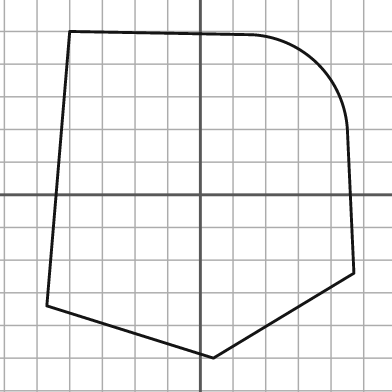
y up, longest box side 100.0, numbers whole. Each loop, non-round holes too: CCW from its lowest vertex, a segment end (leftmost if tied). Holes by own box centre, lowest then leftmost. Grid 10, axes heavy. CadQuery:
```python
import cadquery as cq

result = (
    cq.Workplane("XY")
    .moveTo(4.0, -50.0)
    .lineTo(47.0, -24.0)
    .lineTo(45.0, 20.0)
    .threePointArc((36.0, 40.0), (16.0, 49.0))
    .lineTo(-40.0, 50.0)
    .lineTo(-47.0, -34.0)
    .close()
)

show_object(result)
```